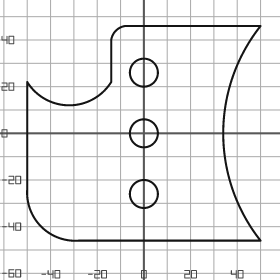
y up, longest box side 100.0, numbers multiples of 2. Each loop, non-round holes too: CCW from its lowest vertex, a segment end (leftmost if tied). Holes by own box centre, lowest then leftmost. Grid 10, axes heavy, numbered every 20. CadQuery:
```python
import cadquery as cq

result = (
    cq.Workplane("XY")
    .moveTo(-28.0, -46.0)
    .lineTo(50.0, -46.0)
    .threePointArc((34.0, 0.0), (50.0, 46.0))
    .lineTo(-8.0, 46.0)
    .threePointArc((-12.0, 44.0), (-14.0, 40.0))
    .lineTo(-14.0, 22.0)
    .threePointArc((-32.0, 12.0), (-50.0, 22.0))
    .lineTo(-50.0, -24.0)
    .threePointArc((-44.0, -40.0), (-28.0, -46.0))
    .close()
    .moveTo(0.0, -26.0)
    .circle(6.0)
    .moveTo(0.0, 0.0)
    .circle(6.0)
    .moveTo(0.0, 26.0)
    .circle(6.0)
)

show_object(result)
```